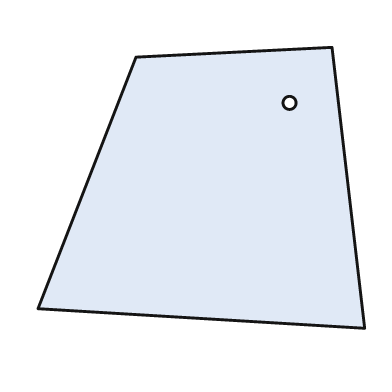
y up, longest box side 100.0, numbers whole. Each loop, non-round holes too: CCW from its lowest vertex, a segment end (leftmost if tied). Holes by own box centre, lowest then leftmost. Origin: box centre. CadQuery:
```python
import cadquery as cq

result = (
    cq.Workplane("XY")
    .moveTo(50.0, -43.0)
    .lineTo(40.0, 43.0)
    .lineTo(-20.0, 40.0)
    .lineTo(-50.0, -37.0)
    .close()
    .moveTo(27.0, 26.0)
    .circle(2.0)
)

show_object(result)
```